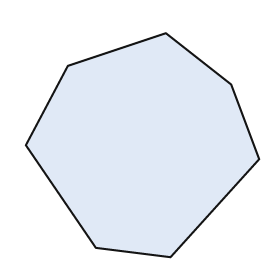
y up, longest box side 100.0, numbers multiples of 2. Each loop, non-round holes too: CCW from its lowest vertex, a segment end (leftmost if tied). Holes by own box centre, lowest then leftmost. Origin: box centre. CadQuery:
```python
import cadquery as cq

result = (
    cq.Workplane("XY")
    .moveTo(12.0, -48.0)
    .lineTo(50.0, -6.0)
    .lineTo(38.0, 26.0)
    .lineTo(10.0, 48.0)
    .lineTo(-32.0, 34.0)
    .lineTo(-50.0, 0.0)
    .lineTo(-20.0, -44.0)
    .close()
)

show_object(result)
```